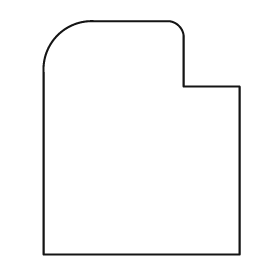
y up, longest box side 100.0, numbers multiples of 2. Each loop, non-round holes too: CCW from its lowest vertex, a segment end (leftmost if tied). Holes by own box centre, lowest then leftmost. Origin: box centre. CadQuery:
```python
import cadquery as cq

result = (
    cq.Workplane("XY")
    .moveTo(-42.0, -50.0)
    .lineTo(42.0, -50.0)
    .lineTo(42.0, 22.0)
    .lineTo(18.0, 22.0)
    .lineTo(18.0, 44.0)
    .threePointArc((16.0, 48.0), (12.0, 50.0))
    .lineTo(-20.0, 50.0)
    .threePointArc((-36.0, 44.0), (-42.0, 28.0))
    .close()
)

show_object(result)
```